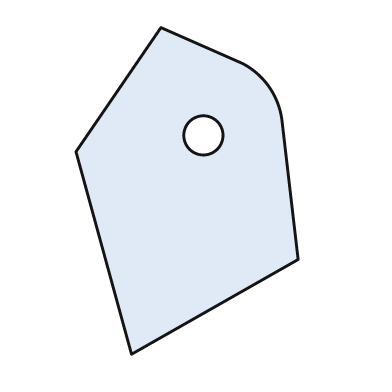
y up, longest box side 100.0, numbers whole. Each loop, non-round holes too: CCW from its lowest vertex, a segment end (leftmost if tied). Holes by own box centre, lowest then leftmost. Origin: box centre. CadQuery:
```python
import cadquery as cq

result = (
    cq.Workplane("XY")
    .moveTo(-17.0, -50.0)
    .lineTo(34.0, -21.0)
    .lineTo(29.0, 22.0)
    .threePointArc((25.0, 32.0), (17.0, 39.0))
    .lineTo(-8.0, 50.0)
    .lineTo(-34.0, 12.0)
    .close()
    .moveTo(5.0, 17.0)
    .circle(6.0)
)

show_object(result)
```